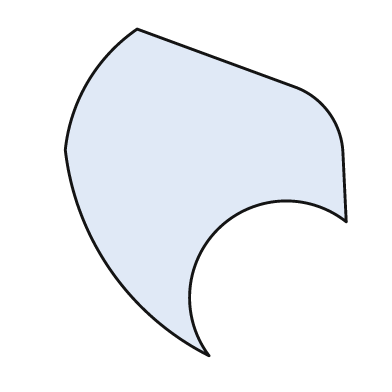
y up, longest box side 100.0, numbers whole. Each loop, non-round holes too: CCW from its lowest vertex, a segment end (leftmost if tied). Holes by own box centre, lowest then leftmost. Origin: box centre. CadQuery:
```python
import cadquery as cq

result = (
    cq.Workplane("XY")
    .moveTo(1.0, -50.0)
    .threePointArc((4.0, -11.0), (43.0, -9.0))
    .lineTo(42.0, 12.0)
    .threePointArc((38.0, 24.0), (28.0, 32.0))
    .lineTo(-21.0, 50.0)
    .threePointArc((-36.0, 34.0), (-43.0, 13.0))
    .threePointArc((-29.0, -24.0), (1.0, -50.0))
    .close()
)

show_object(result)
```